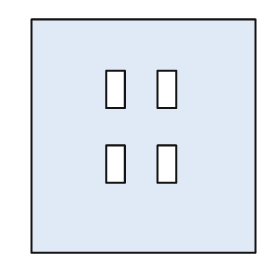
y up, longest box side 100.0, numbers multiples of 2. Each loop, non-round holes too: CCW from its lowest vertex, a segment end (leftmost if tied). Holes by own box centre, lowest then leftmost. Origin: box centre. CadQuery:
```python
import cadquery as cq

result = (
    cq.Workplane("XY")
    .moveTo(-48.0, -50.0)
    .lineTo(48.0, -50.0)
    .lineTo(48.0, 50.0)
    .lineTo(-48.0, 50.0)
    .close()
    .moveTo(-16.0, -20.0)
    .lineTo(-8.0, -20.0)
    .lineTo(-8.0, -4.0)
    .lineTo(-16.0, -4.0)
    .close()
    .moveTo(6.0, -20.0)
    .lineTo(14.0, -20.0)
    .lineTo(14.0, -4.0)
    .lineTo(6.0, -4.0)
    .close()
    .moveTo(-16.0, 12.0)
    .lineTo(-8.0, 12.0)
    .lineTo(-8.0, 28.0)
    .lineTo(-16.0, 28.0)
    .close()
    .moveTo(6.0, 12.0)
    .lineTo(14.0, 12.0)
    .lineTo(14.0, 28.0)
    .lineTo(6.0, 28.0)
    .close()
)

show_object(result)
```